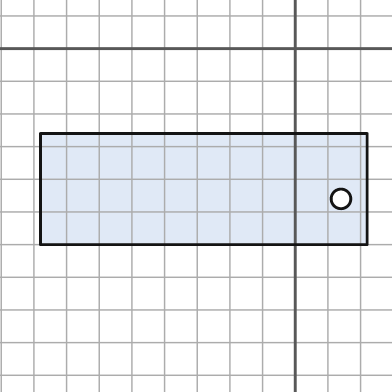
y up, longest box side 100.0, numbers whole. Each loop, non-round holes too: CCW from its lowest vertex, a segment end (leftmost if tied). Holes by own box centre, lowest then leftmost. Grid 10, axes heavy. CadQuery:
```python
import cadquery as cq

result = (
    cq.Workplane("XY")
    .moveTo(-78.0, -60.0)
    .lineTo(22.0, -60.0)
    .lineTo(22.0, -26.0)
    .lineTo(-78.0, -26.0)
    .close()
    .moveTo(14.0, -46.0)
    .circle(3.0)
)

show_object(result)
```